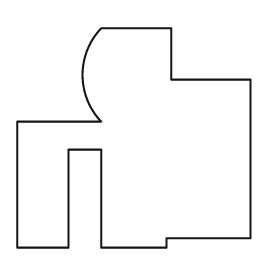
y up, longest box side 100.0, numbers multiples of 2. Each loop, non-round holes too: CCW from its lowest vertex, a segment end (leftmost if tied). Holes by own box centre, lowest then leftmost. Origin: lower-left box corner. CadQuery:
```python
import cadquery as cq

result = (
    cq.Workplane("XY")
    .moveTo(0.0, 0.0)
    .lineTo(22.0, 0.0)
    .lineTo(22.0, 42.0)
    .lineTo(36.0, 42.0)
    .lineTo(36.0, 0.0)
    .lineTo(64.0, 0.0)
    .lineTo(64.0, 4.0)
    .lineTo(100.0, 4.0)
    .lineTo(100.0, 72.0)
    .lineTo(66.0, 72.0)
    .lineTo(66.0, 94.0)
    .lineTo(36.0, 94.0)
    .threePointArc((28.0, 74.0), (36.0, 54.0))
    .lineTo(0.0, 54.0)
    .close()
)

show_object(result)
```